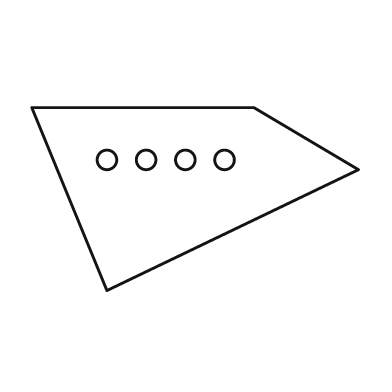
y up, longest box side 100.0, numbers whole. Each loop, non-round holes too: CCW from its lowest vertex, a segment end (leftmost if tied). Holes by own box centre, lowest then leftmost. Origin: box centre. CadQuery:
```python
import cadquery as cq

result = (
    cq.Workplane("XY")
    .moveTo(-27.0, -28.0)
    .lineTo(50.0, 9.0)
    .lineTo(18.0, 28.0)
    .lineTo(-50.0, 28.0)
    .close()
    .moveTo(-27.0, 12.0)
    .circle(3.0)
    .moveTo(-15.0, 12.0)
    .circle(3.0)
    .moveTo(-3.0, 12.0)
    .circle(3.0)
    .moveTo(9.0, 12.0)
    .circle(3.0)
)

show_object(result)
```